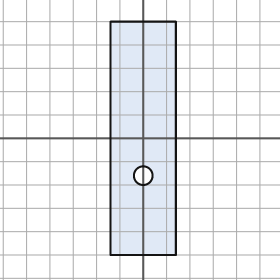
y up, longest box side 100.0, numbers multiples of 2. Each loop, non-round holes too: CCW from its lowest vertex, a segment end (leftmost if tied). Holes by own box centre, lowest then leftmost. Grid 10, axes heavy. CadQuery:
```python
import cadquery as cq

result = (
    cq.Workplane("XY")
    .moveTo(-14.0, -50.0)
    .lineTo(14.0, -50.0)
    .lineTo(14.0, 50.0)
    .lineTo(-14.0, 50.0)
    .close()
    .moveTo(0.0, -16.0)
    .circle(4.0)
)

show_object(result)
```